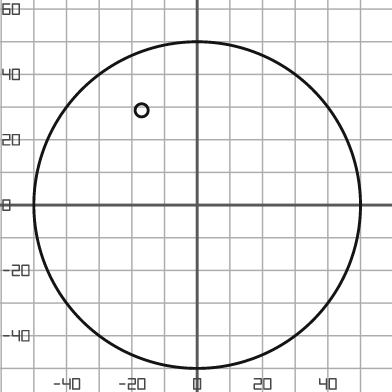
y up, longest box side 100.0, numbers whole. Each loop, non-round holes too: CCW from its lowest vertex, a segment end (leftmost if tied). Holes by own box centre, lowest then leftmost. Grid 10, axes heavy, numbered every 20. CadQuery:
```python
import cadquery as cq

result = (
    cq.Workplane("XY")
    .moveTo(0.0, 0.0)
    .circle(50.0)
    .moveTo(-17.0, 29.0)
    .circle(2.0)
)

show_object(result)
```